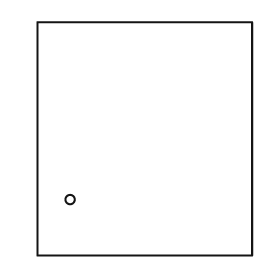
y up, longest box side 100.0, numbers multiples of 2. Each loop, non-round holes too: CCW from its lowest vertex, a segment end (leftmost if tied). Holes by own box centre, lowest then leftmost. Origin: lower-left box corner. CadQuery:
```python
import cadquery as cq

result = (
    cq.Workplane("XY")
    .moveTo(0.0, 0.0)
    .lineTo(92.0, 0.0)
    .lineTo(92.0, 100.0)
    .lineTo(0.0, 100.0)
    .close()
    .moveTo(14.0, 24.0)
    .circle(2.0)
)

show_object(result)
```